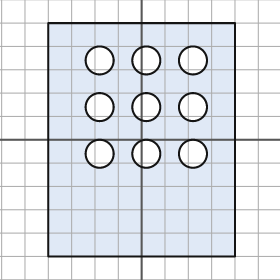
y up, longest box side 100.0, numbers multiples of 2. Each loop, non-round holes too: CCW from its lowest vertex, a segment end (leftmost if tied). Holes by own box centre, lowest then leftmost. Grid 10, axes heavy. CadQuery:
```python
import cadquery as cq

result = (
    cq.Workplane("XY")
    .moveTo(-40.0, -50.0)
    .lineTo(40.0, -50.0)
    .lineTo(40.0, 50.0)
    .lineTo(-40.0, 50.0)
    .close()
    .moveTo(-18.0, -6.0)
    .circle(6.0)
    .moveTo(2.0, -6.0)
    .circle(6.0)
    .moveTo(22.0, -6.0)
    .circle(6.0)
    .moveTo(-18.0, 14.0)
    .circle(6.0)
    .moveTo(2.0, 14.0)
    .circle(6.0)
    .moveTo(22.0, 14.0)
    .circle(6.0)
    .moveTo(-18.0, 34.0)
    .circle(6.0)
    .moveTo(2.0, 34.0)
    .circle(6.0)
    .moveTo(22.0, 34.0)
    .circle(6.0)
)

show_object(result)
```